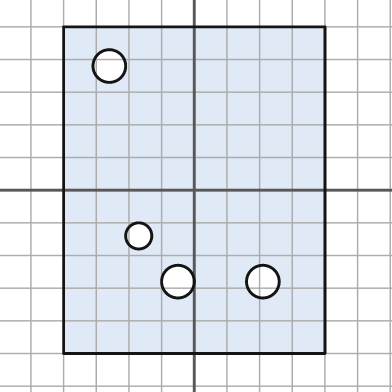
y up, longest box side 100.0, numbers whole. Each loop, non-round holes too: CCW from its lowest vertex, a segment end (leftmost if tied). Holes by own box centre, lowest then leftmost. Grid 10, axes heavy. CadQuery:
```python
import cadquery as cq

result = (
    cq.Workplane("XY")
    .moveTo(-40.0, -50.0)
    .lineTo(40.0, -50.0)
    .lineTo(40.0, 50.0)
    .lineTo(-40.0, 50.0)
    .close()
    .moveTo(-5.0, -28.0)
    .circle(5.0)
    .moveTo(21.0, -28.0)
    .circle(5.0)
    .moveTo(-17.0, -14.0)
    .circle(4.0)
    .moveTo(-26.0, 38.0)
    .circle(5.0)
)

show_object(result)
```